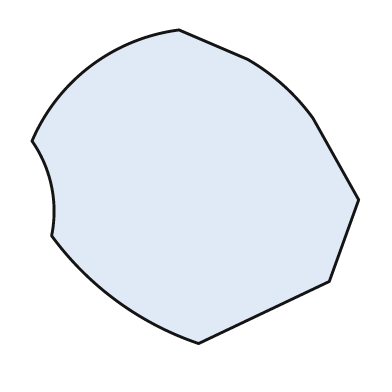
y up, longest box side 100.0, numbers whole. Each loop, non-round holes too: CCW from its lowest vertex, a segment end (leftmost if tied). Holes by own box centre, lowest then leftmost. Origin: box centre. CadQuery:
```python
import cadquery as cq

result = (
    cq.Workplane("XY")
    .moveTo(1.0, -48.0)
    .lineTo(41.0, -29.0)
    .lineTo(50.0, -4.0)
    .lineTo(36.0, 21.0)
    .threePointArc((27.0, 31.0), (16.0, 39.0))
    .lineTo(-5.0, 48.0)
    .threePointArc((-32.0, 37.0), (-50.0, 14.0))
    .threePointArc((-44.0, 0.0), (-44.0, -15.0))
    .threePointArc((-24.0, -35.0), (1.0, -48.0))
    .close()
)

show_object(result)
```